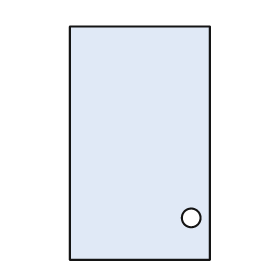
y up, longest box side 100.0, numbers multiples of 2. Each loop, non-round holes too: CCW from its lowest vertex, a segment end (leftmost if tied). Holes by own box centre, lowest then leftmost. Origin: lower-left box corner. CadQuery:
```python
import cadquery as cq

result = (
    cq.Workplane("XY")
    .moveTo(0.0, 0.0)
    .lineTo(60.0, 0.0)
    .lineTo(60.0, 100.0)
    .lineTo(0.0, 100.0)
    .close()
    .moveTo(52.0, 18.0)
    .circle(4.0)
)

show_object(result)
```